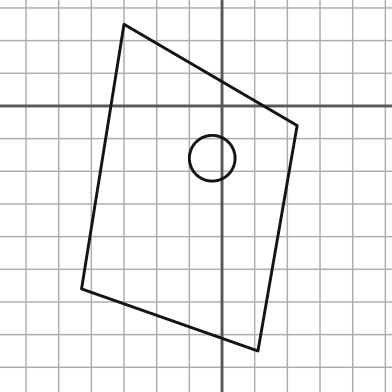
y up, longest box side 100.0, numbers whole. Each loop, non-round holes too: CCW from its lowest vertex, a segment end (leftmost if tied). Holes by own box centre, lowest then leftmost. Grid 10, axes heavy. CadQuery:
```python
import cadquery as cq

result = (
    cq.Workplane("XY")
    .moveTo(11.0, -75.0)
    .lineTo(23.0, -6.0)
    .lineTo(-30.0, 25.0)
    .lineTo(-43.0, -56.0)
    .close()
    .moveTo(-3.0, -16.0)
    .circle(7.0)
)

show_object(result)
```